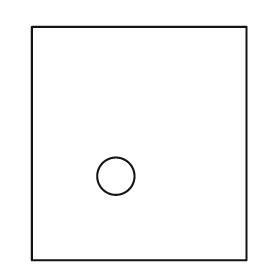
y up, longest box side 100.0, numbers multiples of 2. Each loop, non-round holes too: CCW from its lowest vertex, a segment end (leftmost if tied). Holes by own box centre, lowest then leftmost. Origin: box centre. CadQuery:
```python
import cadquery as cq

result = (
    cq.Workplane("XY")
    .moveTo(-46.0, -50.0)
    .lineTo(46.0, -50.0)
    .lineTo(46.0, 50.0)
    .lineTo(-46.0, 50.0)
    .close()
    .moveTo(-10.0, -14.0)
    .circle(8.0)
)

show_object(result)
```